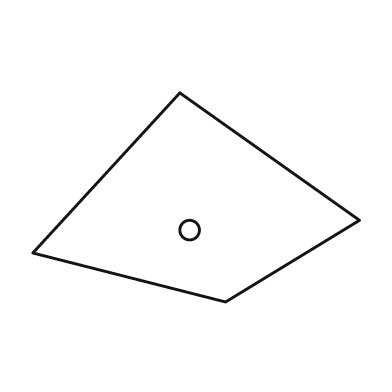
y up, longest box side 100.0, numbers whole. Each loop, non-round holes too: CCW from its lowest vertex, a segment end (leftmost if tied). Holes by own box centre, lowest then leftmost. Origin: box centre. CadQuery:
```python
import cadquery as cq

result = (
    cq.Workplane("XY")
    .moveTo(9.0, -32.0)
    .lineTo(50.0, -7.0)
    .lineTo(-5.0, 32.0)
    .lineTo(-50.0, -17.0)
    .close()
    .moveTo(-2.0, -10.0)
    .circle(3.0)
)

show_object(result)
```